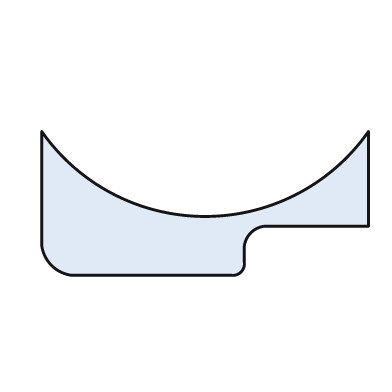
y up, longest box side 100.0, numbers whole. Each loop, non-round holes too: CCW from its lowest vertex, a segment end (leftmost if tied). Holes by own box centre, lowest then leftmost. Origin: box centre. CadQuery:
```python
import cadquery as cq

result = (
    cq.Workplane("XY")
    .moveTo(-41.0, -22.0)
    .lineTo(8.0, -22.0)
    .threePointArc((11.0, -21.0), (12.0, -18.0))
    .lineTo(12.0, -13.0)
    .threePointArc((14.0, -9.0), (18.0, -7.0))
    .lineTo(50.0, -7.0)
    .lineTo(50.0, 22.0)
    .threePointArc((0.0, -4.0), (-50.0, 22.0))
    .lineTo(-50.0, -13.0)
    .threePointArc((-47.0, -19.0), (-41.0, -22.0))
    .close()
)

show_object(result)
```